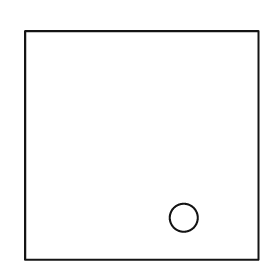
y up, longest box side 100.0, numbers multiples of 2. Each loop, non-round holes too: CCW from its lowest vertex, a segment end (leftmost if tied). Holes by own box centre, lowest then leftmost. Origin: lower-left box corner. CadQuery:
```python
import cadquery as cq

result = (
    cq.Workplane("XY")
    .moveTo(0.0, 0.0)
    .lineTo(100.0, 0.0)
    .lineTo(100.0, 98.0)
    .lineTo(0.0, 98.0)
    .close()
    .moveTo(68.0, 18.0)
    .circle(6.0)
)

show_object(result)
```